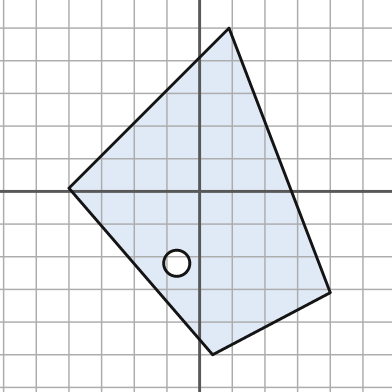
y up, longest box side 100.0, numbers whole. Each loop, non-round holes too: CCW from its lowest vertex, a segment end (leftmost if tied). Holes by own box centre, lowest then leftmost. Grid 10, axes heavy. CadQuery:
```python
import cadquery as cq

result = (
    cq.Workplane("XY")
    .moveTo(4.0, -50.0)
    .lineTo(40.0, -31.0)
    .lineTo(9.0, 50.0)
    .lineTo(-40.0, 1.0)
    .close()
    .moveTo(-7.0, -22.0)
    .circle(4.0)
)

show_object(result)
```